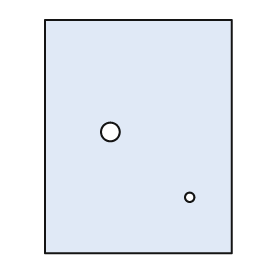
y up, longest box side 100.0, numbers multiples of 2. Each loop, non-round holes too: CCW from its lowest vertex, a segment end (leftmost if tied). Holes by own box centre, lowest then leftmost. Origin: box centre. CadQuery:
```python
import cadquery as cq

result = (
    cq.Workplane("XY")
    .moveTo(-40.0, -50.0)
    .lineTo(40.0, -50.0)
    .lineTo(40.0, 50.0)
    .lineTo(-40.0, 50.0)
    .close()
    .moveTo(22.0, -26.0)
    .circle(2.0)
    .moveTo(-12.0, 2.0)
    .circle(4.0)
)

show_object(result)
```